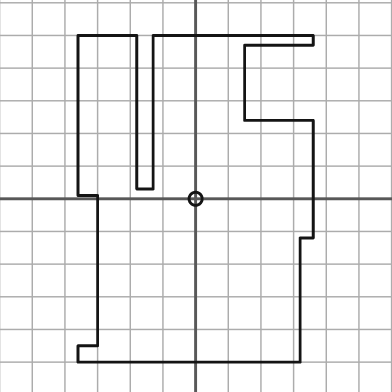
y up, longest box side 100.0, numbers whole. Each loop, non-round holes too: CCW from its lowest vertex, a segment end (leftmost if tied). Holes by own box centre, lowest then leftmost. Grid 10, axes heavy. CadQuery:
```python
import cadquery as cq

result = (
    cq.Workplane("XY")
    .moveTo(-36.0, -50.0)
    .lineTo(32.0, -50.0)
    .lineTo(32.0, -12.0)
    .lineTo(36.0, -12.0)
    .lineTo(36.0, 24.0)
    .lineTo(15.0, 24.0)
    .lineTo(15.0, 47.0)
    .lineTo(36.0, 47.0)
    .lineTo(36.0, 50.0)
    .lineTo(-13.0, 50.0)
    .lineTo(-13.0, 3.0)
    .lineTo(-18.0, 3.0)
    .lineTo(-18.0, 50.0)
    .lineTo(-36.0, 50.0)
    .lineTo(-36.0, 1.0)
    .lineTo(-30.0, 1.0)
    .lineTo(-30.0, -45.0)
    .lineTo(-36.0, -45.0)
    .close()
    .moveTo(0.0, 0.0)
    .circle(2.0)
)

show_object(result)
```